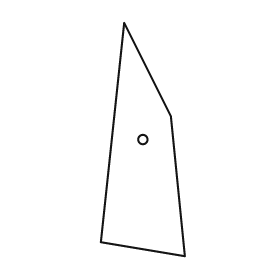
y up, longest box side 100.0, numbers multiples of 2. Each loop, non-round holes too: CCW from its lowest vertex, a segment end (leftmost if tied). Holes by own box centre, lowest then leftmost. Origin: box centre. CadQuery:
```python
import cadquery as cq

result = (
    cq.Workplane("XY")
    .moveTo(18.0, -50.0)
    .lineTo(12.0, 10.0)
    .lineTo(-8.0, 50.0)
    .lineTo(-18.0, -44.0)
    .close()
    .moveTo(0.0, 0.0)
    .circle(2.0)
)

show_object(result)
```